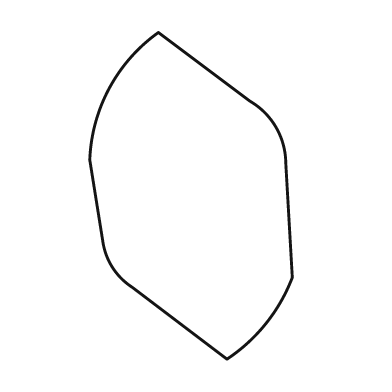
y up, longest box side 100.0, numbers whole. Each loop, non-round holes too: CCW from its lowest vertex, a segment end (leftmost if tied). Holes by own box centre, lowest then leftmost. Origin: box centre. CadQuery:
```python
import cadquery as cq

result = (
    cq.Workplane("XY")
    .moveTo(11.0, -50.0)
    .threePointArc((23.0, -39.0), (31.0, -25.0))
    .lineTo(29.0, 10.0)
    .threePointArc((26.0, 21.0), (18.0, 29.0))
    .lineTo(-10.0, 50.0)
    .threePointArc((-25.0, 33.0), (-31.0, 11.0))
    .lineTo(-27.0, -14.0)
    .threePointArc((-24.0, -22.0), (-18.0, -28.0))
    .close()
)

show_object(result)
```